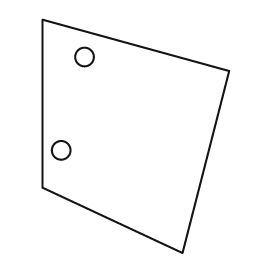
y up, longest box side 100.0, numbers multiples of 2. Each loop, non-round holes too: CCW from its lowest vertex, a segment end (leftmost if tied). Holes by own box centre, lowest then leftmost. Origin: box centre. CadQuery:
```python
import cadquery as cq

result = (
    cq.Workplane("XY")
    .moveTo(20.0, -50.0)
    .lineTo(40.0, 28.0)
    .lineTo(-40.0, 50.0)
    .lineTo(-40.0, -22.0)
    .close()
    .moveTo(-32.0, -6.0)
    .circle(4.0)
    .moveTo(-22.0, 34.0)
    .circle(4.0)
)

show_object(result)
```